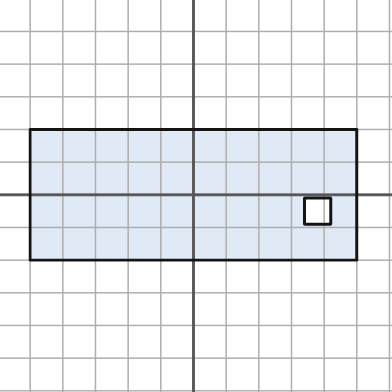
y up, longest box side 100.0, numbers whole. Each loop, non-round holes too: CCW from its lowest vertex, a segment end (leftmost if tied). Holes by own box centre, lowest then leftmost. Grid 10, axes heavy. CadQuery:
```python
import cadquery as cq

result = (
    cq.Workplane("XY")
    .moveTo(-50.0, -20.0)
    .lineTo(50.0, -20.0)
    .lineTo(50.0, 20.0)
    .lineTo(-50.0, 20.0)
    .close()
    .moveTo(34.0, -9.0)
    .lineTo(42.0, -9.0)
    .lineTo(42.0, -1.0)
    .lineTo(34.0, -1.0)
    .close()
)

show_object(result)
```